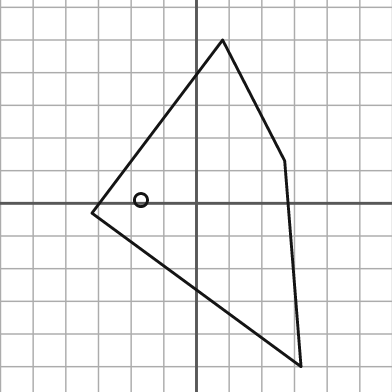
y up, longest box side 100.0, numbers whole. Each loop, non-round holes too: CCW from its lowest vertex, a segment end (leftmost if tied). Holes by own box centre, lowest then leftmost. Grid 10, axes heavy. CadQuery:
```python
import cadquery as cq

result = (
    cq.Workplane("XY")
    .moveTo(32.0, -50.0)
    .lineTo(27.0, 13.0)
    .lineTo(8.0, 50.0)
    .lineTo(-32.0, -3.0)
    .close()
    .moveTo(-17.0, 1.0)
    .circle(2.0)
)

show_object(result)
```